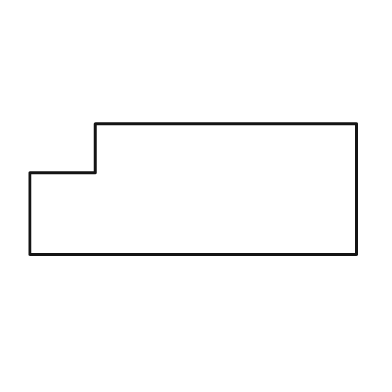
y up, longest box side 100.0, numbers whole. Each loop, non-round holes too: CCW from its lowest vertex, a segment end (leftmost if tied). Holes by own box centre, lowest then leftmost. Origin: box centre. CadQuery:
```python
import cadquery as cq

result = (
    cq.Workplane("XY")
    .moveTo(-50.0, -20.0)
    .lineTo(50.0, -20.0)
    .lineTo(50.0, 20.0)
    .lineTo(-30.0, 20.0)
    .lineTo(-30.0, 5.0)
    .lineTo(-50.0, 5.0)
    .close()
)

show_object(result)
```